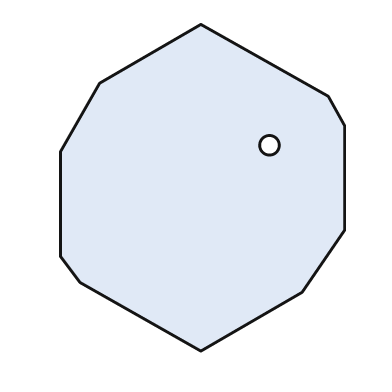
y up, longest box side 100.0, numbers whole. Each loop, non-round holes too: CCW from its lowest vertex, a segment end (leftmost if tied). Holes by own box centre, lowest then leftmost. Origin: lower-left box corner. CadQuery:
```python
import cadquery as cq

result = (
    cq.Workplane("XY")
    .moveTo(43.0, 0.0)
    .lineTo(74.0, 18.0)
    .lineTo(87.0, 37.0)
    .lineTo(87.0, 69.0)
    .lineTo(82.0, 78.0)
    .lineTo(43.0, 100.0)
    .lineTo(12.0, 82.0)
    .lineTo(0.0, 61.0)
    .lineTo(0.0, 29.0)
    .lineTo(6.0, 21.0)
    .close()
    .moveTo(64.0, 63.0)
    .circle(3.0)
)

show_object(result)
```